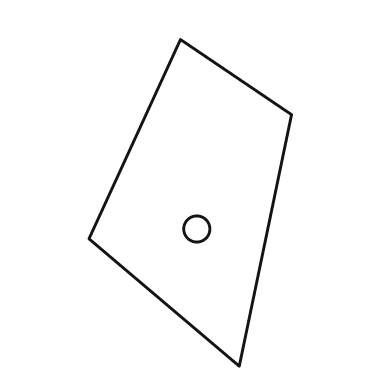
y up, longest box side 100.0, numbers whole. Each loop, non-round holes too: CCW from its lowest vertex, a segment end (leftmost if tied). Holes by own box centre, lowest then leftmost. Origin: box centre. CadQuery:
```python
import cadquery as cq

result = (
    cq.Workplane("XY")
    .moveTo(15.0, -50.0)
    .lineTo(31.0, 27.0)
    .lineTo(-3.0, 50.0)
    .lineTo(-31.0, -11.0)
    .close()
    .moveTo(2.0, -8.0)
    .circle(4.0)
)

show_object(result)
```